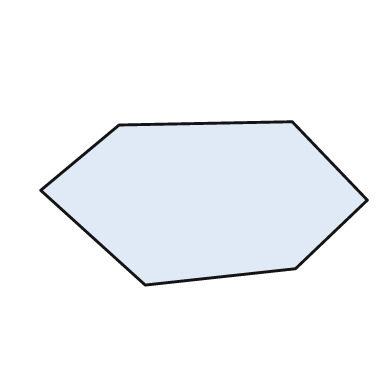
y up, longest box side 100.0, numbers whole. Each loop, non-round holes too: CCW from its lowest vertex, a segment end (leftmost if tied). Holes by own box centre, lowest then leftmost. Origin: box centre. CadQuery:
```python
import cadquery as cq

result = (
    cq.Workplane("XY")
    .moveTo(-18.0, -25.0)
    .lineTo(28.0, -20.0)
    .lineTo(50.0, 1.0)
    .lineTo(27.0, 25.0)
    .lineTo(-26.0, 24.0)
    .lineTo(-50.0, 4.0)
    .close()
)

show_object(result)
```